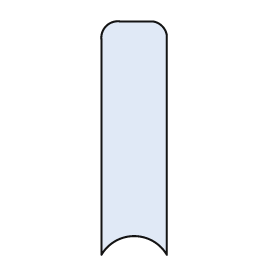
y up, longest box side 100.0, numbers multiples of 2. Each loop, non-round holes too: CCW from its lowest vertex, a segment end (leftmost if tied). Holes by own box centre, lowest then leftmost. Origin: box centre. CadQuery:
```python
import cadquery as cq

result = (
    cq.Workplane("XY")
    .moveTo(-14.0, -50.0)
    .threePointArc((0.0, -42.0), (14.0, -50.0))
    .lineTo(14.0, 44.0)
    .threePointArc((12.0, 48.0), (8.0, 50.0))
    .lineTo(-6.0, 50.0)
    .threePointArc((-12.0, 48.0), (-14.0, 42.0))
    .close()
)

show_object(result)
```